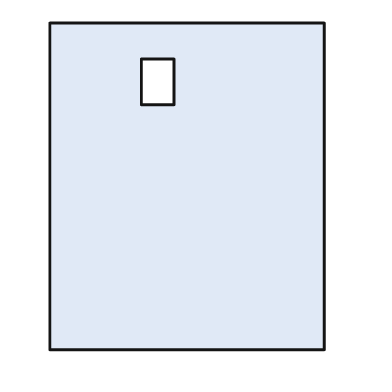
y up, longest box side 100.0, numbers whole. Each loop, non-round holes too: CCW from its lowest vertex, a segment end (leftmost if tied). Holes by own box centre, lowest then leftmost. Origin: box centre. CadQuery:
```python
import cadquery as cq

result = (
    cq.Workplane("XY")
    .moveTo(-42.0, -50.0)
    .lineTo(42.0, -50.0)
    .lineTo(42.0, 50.0)
    .lineTo(-42.0, 50.0)
    .close()
    .moveTo(-14.0, 25.0)
    .lineTo(-4.0, 25.0)
    .lineTo(-4.0, 39.0)
    .lineTo(-14.0, 39.0)
    .close()
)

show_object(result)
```